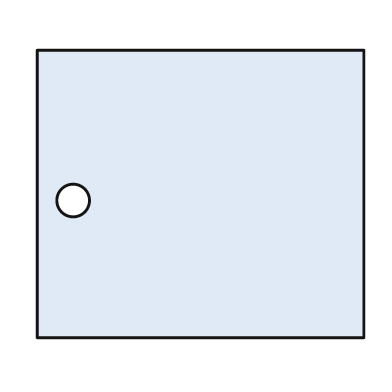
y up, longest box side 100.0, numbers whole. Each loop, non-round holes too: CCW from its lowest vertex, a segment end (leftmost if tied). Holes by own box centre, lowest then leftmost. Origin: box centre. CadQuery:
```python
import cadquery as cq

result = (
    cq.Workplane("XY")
    .moveTo(-50.0, -44.0)
    .lineTo(50.0, -44.0)
    .lineTo(50.0, 44.0)
    .lineTo(-50.0, 44.0)
    .close()
    .moveTo(-39.0, -2.0)
    .circle(5.0)
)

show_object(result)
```